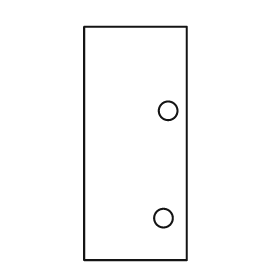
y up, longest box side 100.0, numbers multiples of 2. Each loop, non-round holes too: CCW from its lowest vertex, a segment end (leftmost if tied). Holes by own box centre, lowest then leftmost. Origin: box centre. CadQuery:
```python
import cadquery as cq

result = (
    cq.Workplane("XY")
    .moveTo(-22.0, -50.0)
    .lineTo(22.0, -50.0)
    .lineTo(22.0, 50.0)
    .lineTo(-22.0, 50.0)
    .close()
    .moveTo(12.0, -32.0)
    .circle(4.0)
    .moveTo(14.0, 14.0)
    .circle(4.0)
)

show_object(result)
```